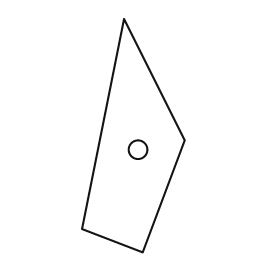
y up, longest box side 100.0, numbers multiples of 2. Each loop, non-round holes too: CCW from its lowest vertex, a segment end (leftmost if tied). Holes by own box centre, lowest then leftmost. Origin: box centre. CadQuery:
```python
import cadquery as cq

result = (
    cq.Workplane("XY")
    .moveTo(4.0, -50.0)
    .lineTo(22.0, -2.0)
    .lineTo(-4.0, 50.0)
    .lineTo(-22.0, -40.0)
    .close()
    .moveTo(2.0, -6.0)
    .circle(4.0)
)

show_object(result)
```